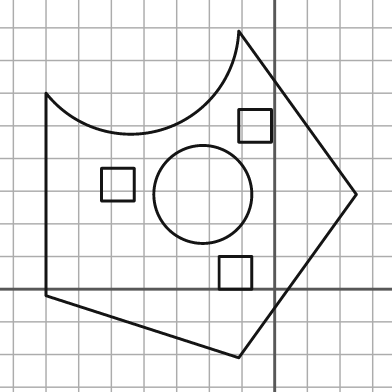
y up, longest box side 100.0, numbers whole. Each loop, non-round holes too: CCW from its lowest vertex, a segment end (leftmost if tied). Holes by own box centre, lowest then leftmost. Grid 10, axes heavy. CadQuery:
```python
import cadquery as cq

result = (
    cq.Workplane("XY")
    .moveTo(-11.0, -21.0)
    .lineTo(25.0, 29.0)
    .lineTo(-11.0, 79.0)
    .threePointArc((-34.0, 49.0), (-70.0, 60.0))
    .lineTo(-70.0, -2.0)
    .close()
    .moveTo(-17.0, 0.0)
    .lineTo(-7.0, 0.0)
    .lineTo(-7.0, 10.0)
    .lineTo(-17.0, 10.0)
    .close()
    .moveTo(-22.0, 29.0)
    .circle(15.0)
    .moveTo(-53.0, 27.0)
    .lineTo(-43.0, 27.0)
    .lineTo(-43.0, 37.0)
    .lineTo(-53.0, 37.0)
    .close()
    .moveTo(-11.0, 45.0)
    .lineTo(-1.0, 45.0)
    .lineTo(-1.0, 55.0)
    .lineTo(-11.0, 55.0)
    .close()
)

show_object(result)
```